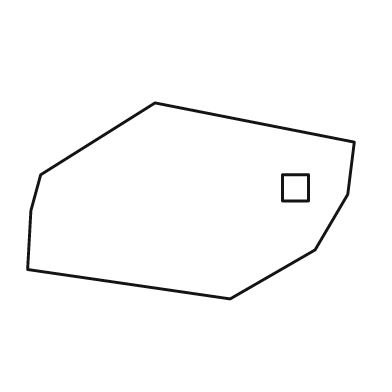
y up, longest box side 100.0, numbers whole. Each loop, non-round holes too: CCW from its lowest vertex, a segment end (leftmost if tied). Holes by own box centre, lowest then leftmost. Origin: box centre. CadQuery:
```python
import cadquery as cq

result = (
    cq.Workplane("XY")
    .moveTo(12.0, -30.0)
    .lineTo(38.0, -15.0)
    .lineTo(48.0, 2.0)
    .lineTo(50.0, 18.0)
    .lineTo(-11.0, 30.0)
    .lineTo(-46.0, 8.0)
    .lineTo(-49.0, -3.0)
    .lineTo(-50.0, -21.0)
    .close()
    .moveTo(28.0, 0.0)
    .lineTo(36.0, 0.0)
    .lineTo(36.0, 8.0)
    .lineTo(28.0, 8.0)
    .close()
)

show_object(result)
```